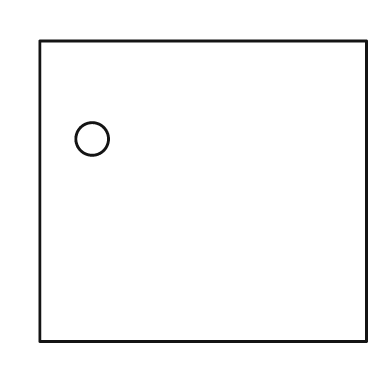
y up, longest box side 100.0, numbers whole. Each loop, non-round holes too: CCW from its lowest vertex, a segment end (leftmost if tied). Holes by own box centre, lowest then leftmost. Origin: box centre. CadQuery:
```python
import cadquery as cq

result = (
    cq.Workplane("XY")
    .moveTo(-50.0, -46.0)
    .lineTo(50.0, -46.0)
    .lineTo(50.0, 46.0)
    .lineTo(-50.0, 46.0)
    .close()
    .moveTo(-34.0, 16.0)
    .circle(5.0)
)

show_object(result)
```